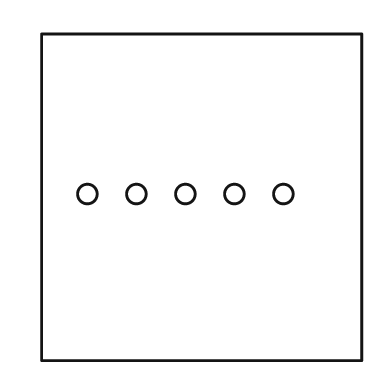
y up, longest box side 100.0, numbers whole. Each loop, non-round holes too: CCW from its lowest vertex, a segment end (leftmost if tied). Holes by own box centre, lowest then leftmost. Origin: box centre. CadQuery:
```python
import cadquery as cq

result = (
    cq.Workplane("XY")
    .moveTo(-49.0, -50.0)
    .lineTo(49.0, -50.0)
    .lineTo(49.0, 50.0)
    .lineTo(-49.0, 50.0)
    .close()
    .moveTo(-35.0, 1.0)
    .circle(3.0)
    .moveTo(-20.0, 1.0)
    .circle(3.0)
    .moveTo(-5.0, 1.0)
    .circle(3.0)
    .moveTo(10.0, 1.0)
    .circle(3.0)
    .moveTo(25.0, 1.0)
    .circle(3.0)
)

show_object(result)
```